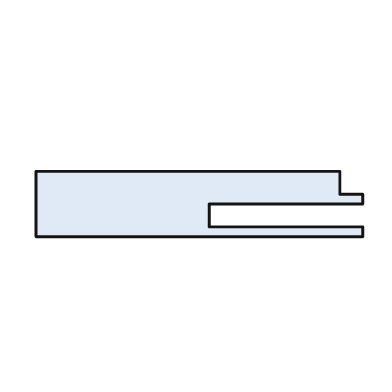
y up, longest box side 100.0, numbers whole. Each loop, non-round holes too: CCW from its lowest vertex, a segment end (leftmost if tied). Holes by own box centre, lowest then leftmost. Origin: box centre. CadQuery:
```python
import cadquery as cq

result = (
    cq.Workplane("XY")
    .moveTo(-50.0, -10.0)
    .lineTo(50.0, -10.0)
    .lineTo(50.0, -7.0)
    .lineTo(3.0, -7.0)
    .lineTo(3.0, 0.0)
    .lineTo(50.0, 0.0)
    .lineTo(50.0, 3.0)
    .lineTo(43.0, 3.0)
    .lineTo(43.0, 10.0)
    .lineTo(-50.0, 10.0)
    .close()
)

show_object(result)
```